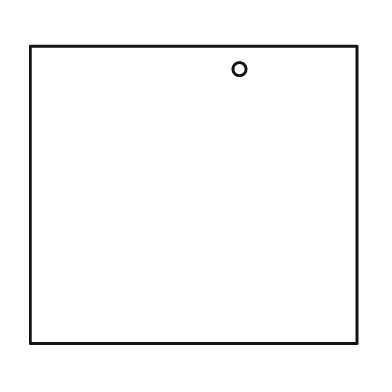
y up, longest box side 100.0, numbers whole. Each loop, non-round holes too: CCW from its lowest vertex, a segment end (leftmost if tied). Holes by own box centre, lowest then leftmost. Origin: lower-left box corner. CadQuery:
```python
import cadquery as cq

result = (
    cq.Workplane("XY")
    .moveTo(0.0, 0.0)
    .lineTo(100.0, 0.0)
    .lineTo(100.0, 91.0)
    .lineTo(0.0, 91.0)
    .close()
    .moveTo(64.0, 84.0)
    .circle(2.0)
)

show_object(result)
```